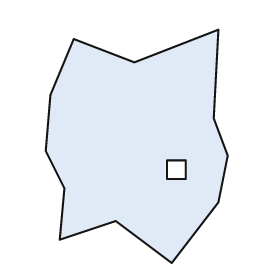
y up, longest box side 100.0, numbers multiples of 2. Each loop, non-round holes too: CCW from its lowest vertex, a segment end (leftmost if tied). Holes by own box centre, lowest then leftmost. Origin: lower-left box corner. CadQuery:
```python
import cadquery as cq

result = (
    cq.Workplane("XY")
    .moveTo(54.0, 0.0)
    .lineTo(74.0, 26.0)
    .lineTo(78.0, 46.0)
    .lineTo(72.0, 62.0)
    .lineTo(74.0, 100.0)
    .lineTo(38.0, 86.0)
    .lineTo(12.0, 96.0)
    .lineTo(2.0, 72.0)
    .lineTo(0.0, 48.0)
    .lineTo(8.0, 32.0)
    .lineTo(6.0, 10.0)
    .lineTo(30.0, 18.0)
    .close()
    .moveTo(52.0, 36.0)
    .lineTo(60.0, 36.0)
    .lineTo(60.0, 44.0)
    .lineTo(52.0, 44.0)
    .close()
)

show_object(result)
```